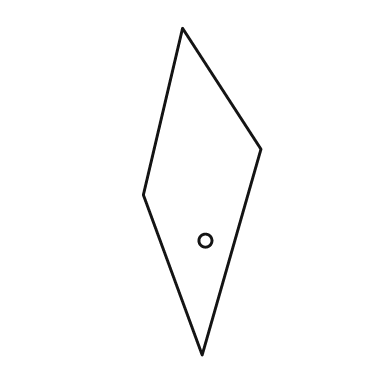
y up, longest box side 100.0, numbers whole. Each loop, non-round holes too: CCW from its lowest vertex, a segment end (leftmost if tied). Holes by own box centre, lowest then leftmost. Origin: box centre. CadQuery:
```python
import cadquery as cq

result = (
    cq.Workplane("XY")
    .moveTo(0.0, -50.0)
    .lineTo(18.0, 13.0)
    .lineTo(-6.0, 50.0)
    .lineTo(-18.0, -1.0)
    .close()
    .moveTo(1.0, -15.0)
    .circle(2.0)
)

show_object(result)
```